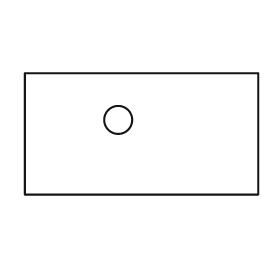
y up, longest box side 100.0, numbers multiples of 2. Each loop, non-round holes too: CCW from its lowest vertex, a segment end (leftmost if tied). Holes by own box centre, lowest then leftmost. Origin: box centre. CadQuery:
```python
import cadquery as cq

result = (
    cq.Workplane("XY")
    .moveTo(-50.0, -26.0)
    .lineTo(50.0, -26.0)
    .lineTo(50.0, 26.0)
    .lineTo(-50.0, 26.0)
    .close()
    .moveTo(-10.0, 6.0)
    .circle(6.0)
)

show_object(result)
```